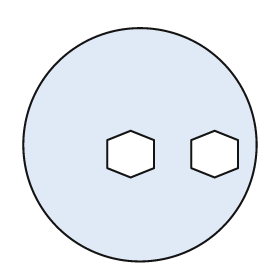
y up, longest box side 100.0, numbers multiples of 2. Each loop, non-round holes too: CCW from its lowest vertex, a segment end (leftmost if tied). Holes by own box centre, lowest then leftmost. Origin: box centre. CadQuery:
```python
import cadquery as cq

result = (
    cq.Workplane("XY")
    .moveTo(0.0, 0.0)
    .circle(50.0)
    .moveTo(-4.0, -14.0)
    .lineTo(6.0, -10.0)
    .lineTo(6.0, 2.0)
    .lineTo(-4.0, 6.0)
    .lineTo(-14.0, 2.0)
    .lineTo(-14.0, -10.0)
    .close()
    .moveTo(32.0, -14.0)
    .lineTo(42.0, -10.0)
    .lineTo(42.0, 2.0)
    .lineTo(32.0, 6.0)
    .lineTo(22.0, 2.0)
    .lineTo(22.0, -10.0)
    .close()
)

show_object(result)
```